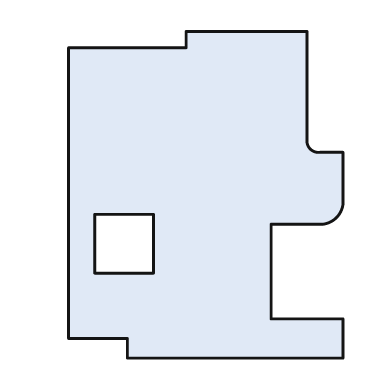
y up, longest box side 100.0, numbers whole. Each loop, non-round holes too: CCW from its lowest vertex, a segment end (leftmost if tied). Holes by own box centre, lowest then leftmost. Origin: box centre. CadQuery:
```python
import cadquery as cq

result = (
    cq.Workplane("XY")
    .moveTo(-24.0, -50.0)
    .lineTo(42.0, -50.0)
    .lineTo(42.0, -38.0)
    .lineTo(20.0, -38.0)
    .lineTo(20.0, -9.0)
    .lineTo(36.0, -9.0)
    .threePointArc((40.0, -7.0), (42.0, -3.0))
    .lineTo(42.0, 13.0)
    .lineTo(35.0, 13.0)
    .threePointArc((32.0, 14.0), (31.0, 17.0))
    .lineTo(31.0, 50.0)
    .lineTo(-6.0, 50.0)
    .lineTo(-6.0, 45.0)
    .lineTo(-42.0, 45.0)
    .lineTo(-42.0, -44.0)
    .lineTo(-24.0, -44.0)
    .close()
    .moveTo(-34.0, -24.0)
    .lineTo(-16.0, -24.0)
    .lineTo(-16.0, -6.0)
    .lineTo(-34.0, -6.0)
    .close()
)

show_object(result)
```